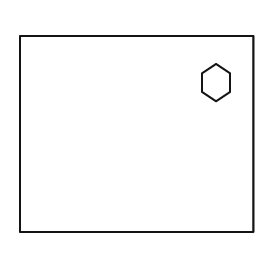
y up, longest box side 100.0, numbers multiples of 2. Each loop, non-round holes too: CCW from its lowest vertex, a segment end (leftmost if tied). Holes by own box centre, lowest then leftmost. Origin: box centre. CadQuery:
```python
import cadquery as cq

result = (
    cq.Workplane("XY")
    .moveTo(-50.0, -42.0)
    .lineTo(50.0, -42.0)
    .lineTo(50.0, 42.0)
    .lineTo(-50.0, 42.0)
    .close()
    .moveTo(34.0, 14.0)
    .lineTo(40.0, 18.0)
    .lineTo(40.0, 26.0)
    .lineTo(34.0, 30.0)
    .lineTo(28.0, 26.0)
    .lineTo(28.0, 18.0)
    .close()
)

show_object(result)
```